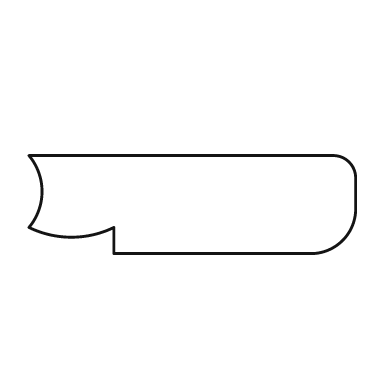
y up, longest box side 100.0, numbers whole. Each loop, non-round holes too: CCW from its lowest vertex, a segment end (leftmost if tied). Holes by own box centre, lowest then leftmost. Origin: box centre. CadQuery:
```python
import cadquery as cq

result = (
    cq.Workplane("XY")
    .moveTo(-24.0, -15.0)
    .lineTo(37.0, -15.0)
    .threePointArc((46.0, -11.0), (50.0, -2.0))
    .lineTo(50.0, 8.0)
    .threePointArc((48.0, 13.0), (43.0, 15.0))
    .lineTo(-50.0, 15.0)
    .threePointArc((-46.0, 4.0), (-50.0, -7.0))
    .threePointArc((-37.0, -10.0), (-24.0, -7.0))
    .close()
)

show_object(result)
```